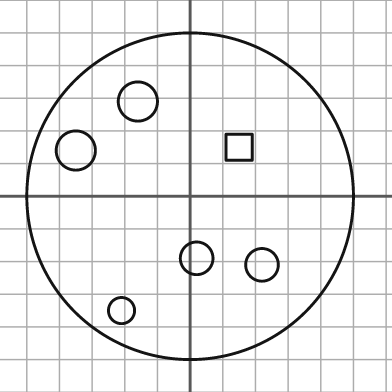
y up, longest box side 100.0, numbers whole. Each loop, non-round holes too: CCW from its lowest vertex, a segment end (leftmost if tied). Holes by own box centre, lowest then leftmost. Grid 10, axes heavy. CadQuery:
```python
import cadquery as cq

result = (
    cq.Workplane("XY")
    .moveTo(0.0, 0.0)
    .circle(50.0)
    .moveTo(-21.0, -35.0)
    .circle(4.0)
    .moveTo(22.0, -21.0)
    .circle(5.0)
    .moveTo(2.0, -19.0)
    .circle(5.0)
    .moveTo(-35.0, 14.0)
    .circle(6.0)
    .moveTo(11.0, 11.0)
    .lineTo(19.0, 11.0)
    .lineTo(19.0, 19.0)
    .lineTo(11.0, 19.0)
    .close()
    .moveTo(-16.0, 29.0)
    .circle(6.0)
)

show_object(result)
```